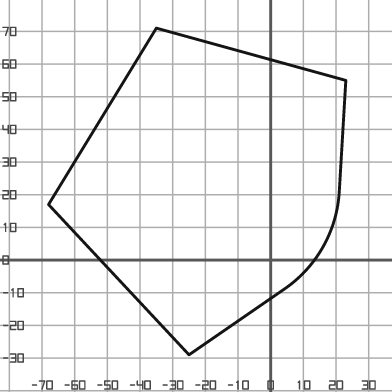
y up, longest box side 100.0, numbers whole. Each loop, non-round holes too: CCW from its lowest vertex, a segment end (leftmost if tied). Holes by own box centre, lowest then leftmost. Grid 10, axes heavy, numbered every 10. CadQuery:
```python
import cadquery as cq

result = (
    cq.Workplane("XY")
    .moveTo(-25.0, -29.0)
    .lineTo(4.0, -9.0)
    .threePointArc((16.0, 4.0), (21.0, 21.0))
    .lineTo(23.0, 55.0)
    .lineTo(-35.0, 71.0)
    .lineTo(-68.0, 17.0)
    .close()
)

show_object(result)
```